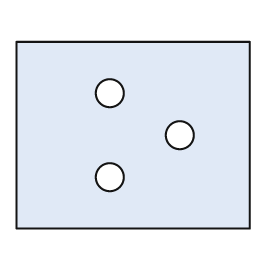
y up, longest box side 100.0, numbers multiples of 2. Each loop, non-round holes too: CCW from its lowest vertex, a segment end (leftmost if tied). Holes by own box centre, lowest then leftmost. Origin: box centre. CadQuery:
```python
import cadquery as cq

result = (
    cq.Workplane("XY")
    .moveTo(-50.0, -40.0)
    .lineTo(50.0, -40.0)
    .lineTo(50.0, 40.0)
    .lineTo(-50.0, 40.0)
    .close()
    .moveTo(-10.0, -18.0)
    .circle(6.0)
    .moveTo(20.0, 0.0)
    .circle(6.0)
    .moveTo(-10.0, 18.0)
    .circle(6.0)
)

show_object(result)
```